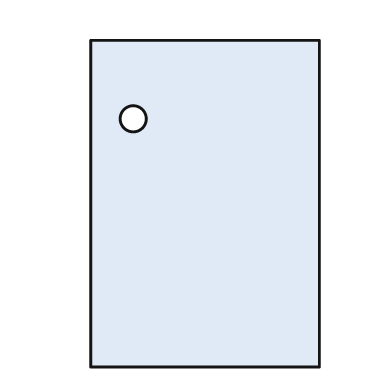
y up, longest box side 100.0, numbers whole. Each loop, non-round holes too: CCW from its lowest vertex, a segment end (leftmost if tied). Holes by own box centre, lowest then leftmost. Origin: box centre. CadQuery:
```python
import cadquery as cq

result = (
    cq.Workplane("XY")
    .moveTo(-35.0, -50.0)
    .lineTo(35.0, -50.0)
    .lineTo(35.0, 50.0)
    .lineTo(-35.0, 50.0)
    .close()
    .moveTo(-22.0, 26.0)
    .circle(4.0)
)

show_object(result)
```